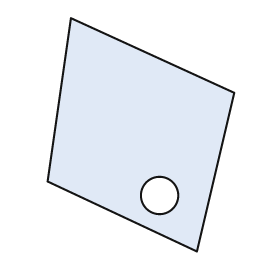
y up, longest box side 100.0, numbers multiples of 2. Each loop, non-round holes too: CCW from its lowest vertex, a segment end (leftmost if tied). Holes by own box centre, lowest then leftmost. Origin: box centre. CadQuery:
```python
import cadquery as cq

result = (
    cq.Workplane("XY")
    .moveTo(24.0, -50.0)
    .lineTo(40.0, 18.0)
    .lineTo(-30.0, 50.0)
    .lineTo(-40.0, -20.0)
    .close()
    .moveTo(8.0, -26.0)
    .circle(8.0)
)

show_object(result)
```